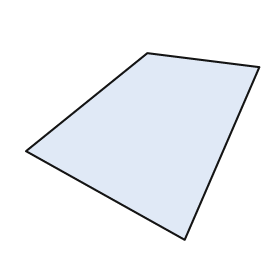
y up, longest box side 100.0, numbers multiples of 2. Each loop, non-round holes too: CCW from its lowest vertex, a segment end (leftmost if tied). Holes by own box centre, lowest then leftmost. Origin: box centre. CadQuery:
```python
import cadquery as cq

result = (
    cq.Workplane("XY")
    .moveTo(18.0, -40.0)
    .lineTo(50.0, 34.0)
    .lineTo(2.0, 40.0)
    .lineTo(-50.0, -2.0)
    .close()
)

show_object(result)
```